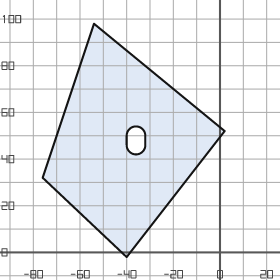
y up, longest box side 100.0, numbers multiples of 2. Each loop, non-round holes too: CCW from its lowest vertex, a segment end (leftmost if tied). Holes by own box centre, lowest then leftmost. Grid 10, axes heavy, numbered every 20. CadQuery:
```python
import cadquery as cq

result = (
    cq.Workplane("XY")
    .moveTo(-40.0, -2.0)
    .lineTo(2.0, 52.0)
    .lineTo(-54.0, 98.0)
    .lineTo(-76.0, 32.0)
    .close()
    .moveTo(-40.0, 46.0)
    .threePointArc((-36.0, 42.0), (-32.0, 46.0))
    .lineTo(-32.0, 50.0)
    .threePointArc((-36.0, 54.0), (-40.0, 50.0))
    .close()
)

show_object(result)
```